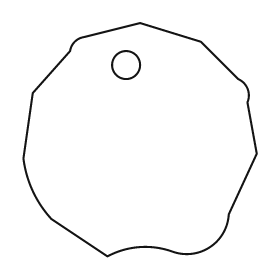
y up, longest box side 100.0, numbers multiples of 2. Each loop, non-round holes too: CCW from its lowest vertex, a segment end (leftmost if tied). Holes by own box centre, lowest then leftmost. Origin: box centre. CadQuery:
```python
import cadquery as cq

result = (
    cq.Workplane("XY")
    .moveTo(-14.0, -50.0)
    .threePointArc((0.0, -46.0), (14.0, -48.0))
    .threePointArc((30.0, -46.0), (38.0, -32.0))
    .lineTo(50.0, -6.0)
    .lineTo(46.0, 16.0)
    .threePointArc((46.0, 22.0), (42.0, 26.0))
    .lineTo(26.0, 42.0)
    .lineTo(0.0, 50.0)
    .lineTo(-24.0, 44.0)
    .threePointArc((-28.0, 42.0), (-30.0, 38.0))
    .lineTo(-46.0, 20.0)
    .lineTo(-50.0, -8.0)
    .threePointArc((-46.0, -22.0), (-38.0, -34.0))
    .close()
    .moveTo(-6.0, 32.0)
    .circle(6.0)
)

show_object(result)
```